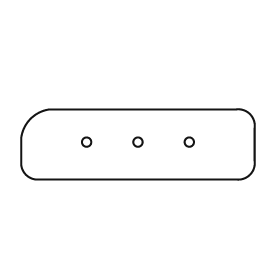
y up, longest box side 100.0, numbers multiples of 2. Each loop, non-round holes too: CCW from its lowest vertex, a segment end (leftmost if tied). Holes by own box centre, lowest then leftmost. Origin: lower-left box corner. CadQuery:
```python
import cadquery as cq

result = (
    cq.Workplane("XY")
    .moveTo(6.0, 0.0)
    .lineTo(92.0, 0.0)
    .threePointArc((98.0, 2.0), (100.0, 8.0))
    .lineTo(100.0, 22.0)
    .threePointArc((98.0, 28.0), (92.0, 30.0))
    .lineTo(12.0, 30.0)
    .threePointArc((4.0, 26.0), (0.0, 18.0))
    .lineTo(0.0, 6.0)
    .threePointArc((2.0, 2.0), (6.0, 0.0))
    .close()
    .moveTo(28.0, 16.0)
    .circle(2.0)
    .moveTo(50.0, 16.0)
    .circle(2.0)
    .moveTo(72.0, 16.0)
    .circle(2.0)
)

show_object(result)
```